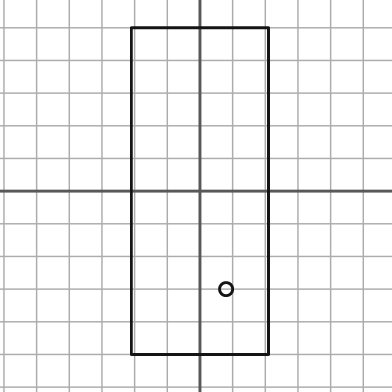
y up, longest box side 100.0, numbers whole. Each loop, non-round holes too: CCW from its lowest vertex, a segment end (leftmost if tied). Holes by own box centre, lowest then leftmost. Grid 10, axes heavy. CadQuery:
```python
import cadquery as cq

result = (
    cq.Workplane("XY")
    .moveTo(-21.0, -50.0)
    .lineTo(21.0, -50.0)
    .lineTo(21.0, 50.0)
    .lineTo(-21.0, 50.0)
    .close()
    .moveTo(8.0, -30.0)
    .circle(2.0)
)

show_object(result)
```